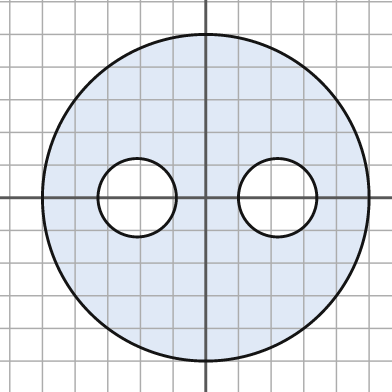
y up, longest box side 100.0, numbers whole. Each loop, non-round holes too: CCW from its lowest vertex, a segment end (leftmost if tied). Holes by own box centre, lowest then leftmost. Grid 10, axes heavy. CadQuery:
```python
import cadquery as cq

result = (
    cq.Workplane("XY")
    .moveTo(0.0, 0.0)
    .circle(50.0)
    .moveTo(-21.0, 0.0)
    .circle(12.0)
    .moveTo(22.0, 0.0)
    .circle(12.0)
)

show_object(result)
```